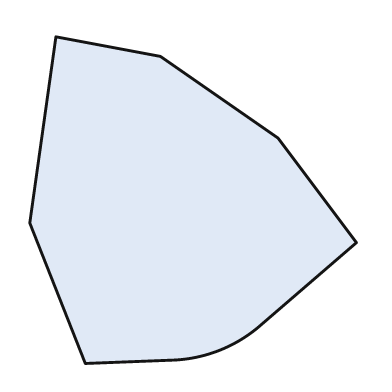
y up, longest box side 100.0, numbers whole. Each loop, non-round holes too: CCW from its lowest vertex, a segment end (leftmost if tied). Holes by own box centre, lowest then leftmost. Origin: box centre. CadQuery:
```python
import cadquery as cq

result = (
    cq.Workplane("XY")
    .moveTo(-33.0, -50.0)
    .lineTo(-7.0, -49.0)
    .threePointArc((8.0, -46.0), (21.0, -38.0))
    .lineTo(50.0, -13.0)
    .lineTo(26.0, 19.0)
    .lineTo(-10.0, 44.0)
    .lineTo(-42.0, 50.0)
    .lineTo(-50.0, -7.0)
    .close()
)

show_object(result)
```